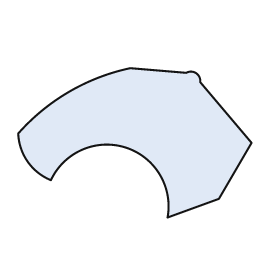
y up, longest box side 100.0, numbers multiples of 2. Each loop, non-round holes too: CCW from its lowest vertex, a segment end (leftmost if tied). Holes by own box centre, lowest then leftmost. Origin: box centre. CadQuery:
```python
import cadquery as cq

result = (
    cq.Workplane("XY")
    .moveTo(14.0, -32.0)
    .lineTo(36.0, -24.0)
    .lineTo(50.0, 0.0)
    .lineTo(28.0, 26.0)
    .threePointArc((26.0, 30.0), (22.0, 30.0))
    .lineTo(-2.0, 32.0)
    .threePointArc((-28.0, 22.0), (-50.0, 4.0))
    .threePointArc((-46.0, -8.0), (-36.0, -16.0))
    .threePointArc((-4.0, -2.0), (14.0, -32.0))
    .close()
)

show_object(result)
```